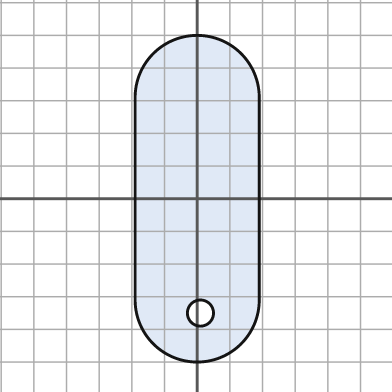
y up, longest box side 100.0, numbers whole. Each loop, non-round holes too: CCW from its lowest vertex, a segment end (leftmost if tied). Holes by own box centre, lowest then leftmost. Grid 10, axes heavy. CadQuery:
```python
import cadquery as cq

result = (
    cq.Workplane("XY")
    .moveTo(-19.0, -31.0)
    .threePointArc((0.0, -50.0), (19.0, -31.0))
    .lineTo(19.0, 31.0)
    .threePointArc((0.0, 50.0), (-19.0, 31.0))
    .close()
    .moveTo(1.0, -35.0)
    .circle(4.0)
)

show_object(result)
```